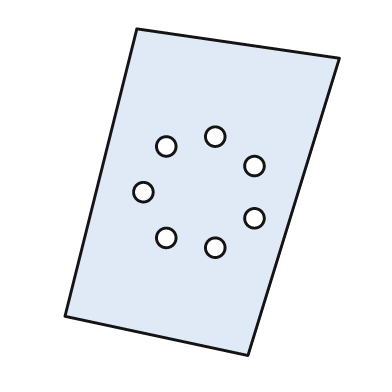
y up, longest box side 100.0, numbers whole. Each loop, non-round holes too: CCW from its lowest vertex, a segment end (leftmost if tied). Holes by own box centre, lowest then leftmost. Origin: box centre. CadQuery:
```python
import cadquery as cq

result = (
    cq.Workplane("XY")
    .moveTo(14.0, -50.0)
    .lineTo(42.0, 41.0)
    .lineTo(-20.0, 50.0)
    .lineTo(-42.0, -38.0)
    .close()
    .moveTo(4.0, -17.0)
    .circle(3.0)
    .moveTo(-11.0, -14.0)
    .circle(3.0)
    .moveTo(16.0, -8.0)
    .circle(3.0)
    .moveTo(-18.0, 0.0)
    .circle(3.0)
    .moveTo(16.0, 8.0)
    .circle(3.0)
    .moveTo(-11.0, 14.0)
    .circle(3.0)
    .moveTo(4.0, 17.0)
    .circle(3.0)
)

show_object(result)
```